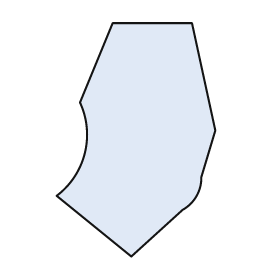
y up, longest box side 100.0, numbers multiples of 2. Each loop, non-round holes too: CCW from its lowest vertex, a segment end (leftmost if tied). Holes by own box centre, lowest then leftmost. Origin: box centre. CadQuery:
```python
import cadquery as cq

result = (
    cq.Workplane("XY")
    .moveTo(-2.0, -50.0)
    .lineTo(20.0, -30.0)
    .threePointArc((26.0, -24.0), (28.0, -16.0))
    .lineTo(34.0, 4.0)
    .lineTo(24.0, 50.0)
    .lineTo(-10.0, 50.0)
    .lineTo(-24.0, 16.0)
    .threePointArc((-22.0, -6.0), (-34.0, -24.0))
    .close()
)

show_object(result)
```